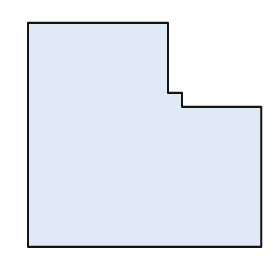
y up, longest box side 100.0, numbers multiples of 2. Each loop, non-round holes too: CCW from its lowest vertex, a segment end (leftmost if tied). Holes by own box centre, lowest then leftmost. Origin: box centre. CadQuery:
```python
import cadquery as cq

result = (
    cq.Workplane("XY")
    .moveTo(-50.0, -48.0)
    .lineTo(50.0, -48.0)
    .lineTo(50.0, 12.0)
    .lineTo(16.0, 12.0)
    .lineTo(16.0, 18.0)
    .lineTo(10.0, 18.0)
    .lineTo(10.0, 48.0)
    .lineTo(-50.0, 48.0)
    .close()
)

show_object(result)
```